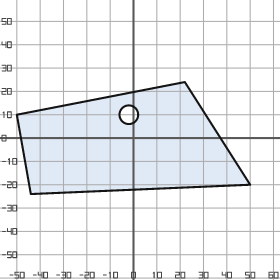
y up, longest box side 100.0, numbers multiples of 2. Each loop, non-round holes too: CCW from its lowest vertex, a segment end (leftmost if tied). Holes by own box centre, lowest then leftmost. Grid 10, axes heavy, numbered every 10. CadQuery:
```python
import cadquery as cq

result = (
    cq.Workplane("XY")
    .moveTo(-44.0, -24.0)
    .lineTo(50.0, -20.0)
    .lineTo(22.0, 24.0)
    .lineTo(-50.0, 10.0)
    .close()
    .moveTo(-2.0, 10.0)
    .circle(4.0)
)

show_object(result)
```